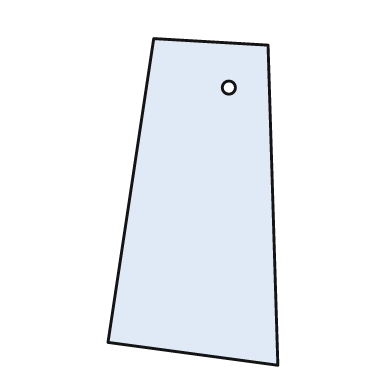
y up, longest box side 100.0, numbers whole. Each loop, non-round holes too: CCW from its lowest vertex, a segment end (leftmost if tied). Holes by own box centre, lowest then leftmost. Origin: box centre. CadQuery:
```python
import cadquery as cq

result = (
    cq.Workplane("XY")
    .moveTo(26.0, -50.0)
    .lineTo(23.0, 48.0)
    .lineTo(-12.0, 50.0)
    .lineTo(-26.0, -43.0)
    .close()
    .moveTo(11.0, 35.0)
    .circle(2.0)
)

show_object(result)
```